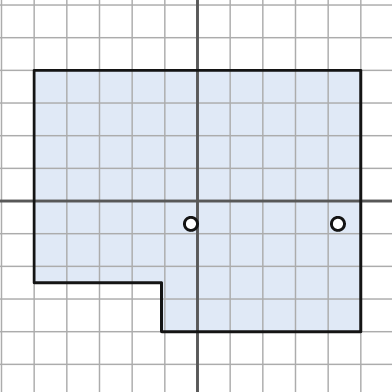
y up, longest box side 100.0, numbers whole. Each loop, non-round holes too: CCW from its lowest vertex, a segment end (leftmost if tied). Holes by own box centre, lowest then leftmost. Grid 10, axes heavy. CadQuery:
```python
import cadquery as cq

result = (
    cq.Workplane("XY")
    .moveTo(-11.0, -40.0)
    .lineTo(50.0, -40.0)
    .lineTo(50.0, 40.0)
    .lineTo(-50.0, 40.0)
    .lineTo(-50.0, -25.0)
    .lineTo(-11.0, -25.0)
    .close()
    .moveTo(-2.0, -7.0)
    .circle(2.0)
    .moveTo(43.0, -7.0)
    .circle(2.0)
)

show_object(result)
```